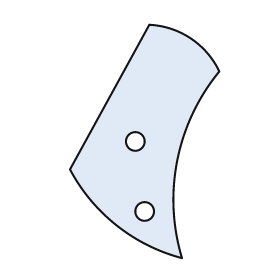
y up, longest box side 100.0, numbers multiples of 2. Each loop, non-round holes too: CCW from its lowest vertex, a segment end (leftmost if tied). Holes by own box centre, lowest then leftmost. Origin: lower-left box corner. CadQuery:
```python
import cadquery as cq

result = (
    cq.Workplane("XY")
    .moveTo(48.0, 0.0)
    .threePointArc((46.0, 42.0), (64.0, 80.0))
    .threePointArc((52.0, 94.0), (34.0, 100.0))
    .lineTo(0.0, 38.0)
    .threePointArc((20.0, 14.0), (48.0, 0.0))
    .close()
    .moveTo(32.0, 20.0)
    .circle(4.0)
    .moveTo(28.0, 50.0)
    .circle(4.0)
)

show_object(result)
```